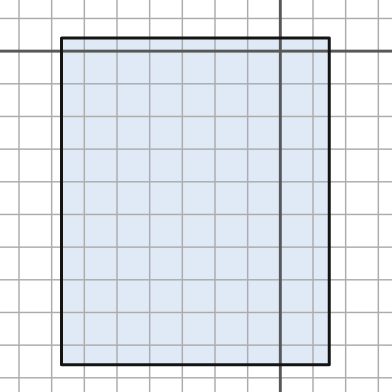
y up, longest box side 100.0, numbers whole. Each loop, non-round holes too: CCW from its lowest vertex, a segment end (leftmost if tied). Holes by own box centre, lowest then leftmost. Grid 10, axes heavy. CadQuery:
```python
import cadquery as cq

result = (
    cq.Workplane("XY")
    .moveTo(-67.0, -96.0)
    .lineTo(15.0, -96.0)
    .lineTo(15.0, 4.0)
    .lineTo(-67.0, 4.0)
    .close()
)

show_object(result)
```